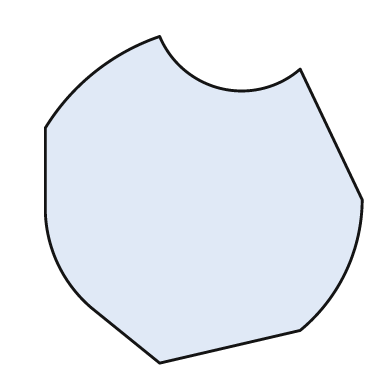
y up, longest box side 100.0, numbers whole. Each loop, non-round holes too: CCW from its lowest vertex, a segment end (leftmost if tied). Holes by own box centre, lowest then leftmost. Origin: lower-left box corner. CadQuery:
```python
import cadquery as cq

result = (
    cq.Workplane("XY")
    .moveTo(35.0, 0.0)
    .lineTo(78.0, 10.0)
    .threePointArc((92.0, 28.0), (97.0, 50.0))
    .lineTo(78.0, 90.0)
    .threePointArc((54.0, 84.0), (35.0, 100.0))
    .threePointArc((15.0, 89.0), (0.0, 72.0))
    .lineTo(0.0, 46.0)
    .threePointArc((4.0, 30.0), (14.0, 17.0))
    .close()
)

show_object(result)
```